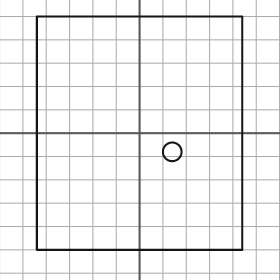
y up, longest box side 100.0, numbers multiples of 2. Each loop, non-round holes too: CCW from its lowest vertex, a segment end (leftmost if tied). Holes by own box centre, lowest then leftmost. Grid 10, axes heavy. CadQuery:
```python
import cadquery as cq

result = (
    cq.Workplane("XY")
    .moveTo(-44.0, -50.0)
    .lineTo(44.0, -50.0)
    .lineTo(44.0, 50.0)
    .lineTo(-44.0, 50.0)
    .close()
    .moveTo(14.0, -8.0)
    .circle(4.0)
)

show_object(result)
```